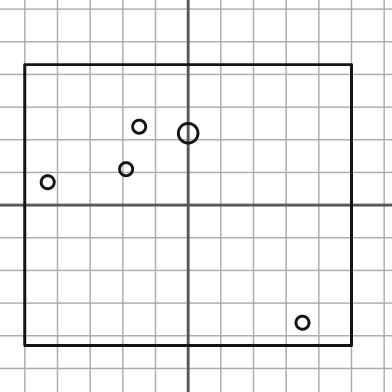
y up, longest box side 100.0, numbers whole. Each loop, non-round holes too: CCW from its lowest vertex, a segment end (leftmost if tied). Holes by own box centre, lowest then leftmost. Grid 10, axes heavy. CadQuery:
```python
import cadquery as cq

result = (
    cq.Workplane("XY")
    .moveTo(-50.0, -43.0)
    .lineTo(50.0, -43.0)
    .lineTo(50.0, 43.0)
    .lineTo(-50.0, 43.0)
    .close()
    .moveTo(35.0, -36.0)
    .circle(2.0)
    .moveTo(-43.0, 7.0)
    .circle(2.0)
    .moveTo(-19.0, 11.0)
    .circle(2.0)
    .moveTo(0.0, 22.0)
    .circle(3.0)
    .moveTo(-15.0, 24.0)
    .circle(2.0)
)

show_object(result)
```